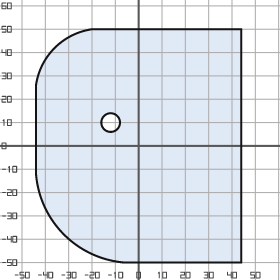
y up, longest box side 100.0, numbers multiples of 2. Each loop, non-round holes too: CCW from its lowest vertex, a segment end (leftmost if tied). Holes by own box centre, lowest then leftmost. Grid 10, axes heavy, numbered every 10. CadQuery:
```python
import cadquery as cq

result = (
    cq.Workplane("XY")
    .moveTo(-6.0, -50.0)
    .lineTo(44.0, -50.0)
    .lineTo(44.0, 50.0)
    .lineTo(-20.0, 50.0)
    .threePointArc((-36.0, 42.0), (-44.0, 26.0))
    .lineTo(-44.0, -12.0)
    .threePointArc((-32.0, -38.0), (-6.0, -50.0))
    .close()
    .moveTo(-12.0, 10.0)
    .circle(4.0)
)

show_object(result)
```